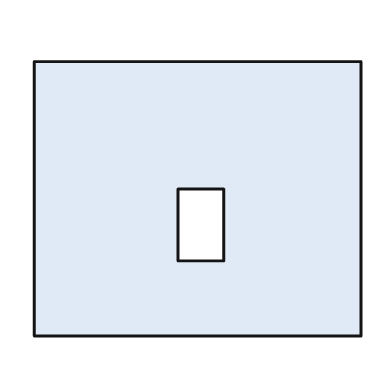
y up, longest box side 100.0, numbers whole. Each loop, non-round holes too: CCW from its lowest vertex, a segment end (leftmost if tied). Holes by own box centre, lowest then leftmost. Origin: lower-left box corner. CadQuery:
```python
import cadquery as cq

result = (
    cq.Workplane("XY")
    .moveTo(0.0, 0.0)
    .lineTo(100.0, 0.0)
    .lineTo(100.0, 84.0)
    .lineTo(0.0, 84.0)
    .close()
    .moveTo(44.0, 23.0)
    .lineTo(58.0, 23.0)
    .lineTo(58.0, 45.0)
    .lineTo(44.0, 45.0)
    .close()
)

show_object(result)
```